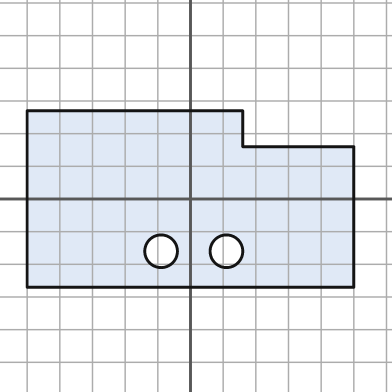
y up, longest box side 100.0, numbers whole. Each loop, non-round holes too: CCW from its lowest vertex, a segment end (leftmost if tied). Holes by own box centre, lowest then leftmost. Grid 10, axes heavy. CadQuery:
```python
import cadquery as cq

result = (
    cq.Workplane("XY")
    .moveTo(-50.0, -27.0)
    .lineTo(50.0, -27.0)
    .lineTo(50.0, 16.0)
    .lineTo(16.0, 16.0)
    .lineTo(16.0, 27.0)
    .lineTo(-50.0, 27.0)
    .close()
    .moveTo(-9.0, -16.0)
    .circle(5.0)
    .moveTo(11.0, -16.0)
    .circle(5.0)
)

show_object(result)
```